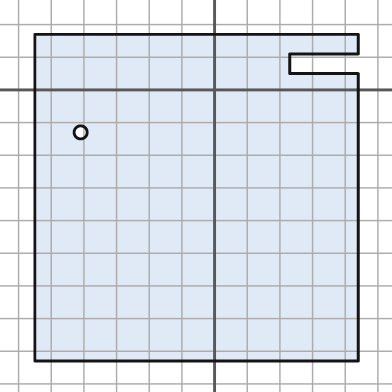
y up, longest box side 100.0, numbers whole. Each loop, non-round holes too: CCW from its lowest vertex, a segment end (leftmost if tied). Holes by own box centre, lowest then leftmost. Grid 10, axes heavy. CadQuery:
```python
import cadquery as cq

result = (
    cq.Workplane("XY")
    .moveTo(-55.0, -83.0)
    .lineTo(44.0, -83.0)
    .lineTo(44.0, 5.0)
    .lineTo(23.0, 5.0)
    .lineTo(23.0, 11.0)
    .lineTo(44.0, 11.0)
    .lineTo(44.0, 17.0)
    .lineTo(-55.0, 17.0)
    .close()
    .moveTo(-41.0, -13.0)
    .circle(2.0)
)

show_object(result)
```